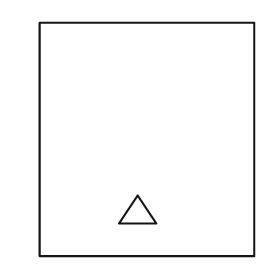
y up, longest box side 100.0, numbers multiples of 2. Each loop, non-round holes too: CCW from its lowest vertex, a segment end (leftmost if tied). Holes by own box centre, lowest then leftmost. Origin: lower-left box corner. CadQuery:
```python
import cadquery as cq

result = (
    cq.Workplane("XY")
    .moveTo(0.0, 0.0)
    .lineTo(92.0, 0.0)
    .lineTo(92.0, 100.0)
    .lineTo(0.0, 100.0)
    .close()
    .moveTo(34.0, 14.0)
    .lineTo(50.0, 14.0)
    .lineTo(42.0, 26.0)
    .close()
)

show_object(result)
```